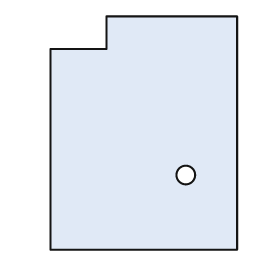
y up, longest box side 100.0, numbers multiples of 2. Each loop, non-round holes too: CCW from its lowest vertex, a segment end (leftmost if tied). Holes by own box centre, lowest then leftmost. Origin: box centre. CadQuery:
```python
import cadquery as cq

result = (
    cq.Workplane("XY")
    .moveTo(-40.0, -50.0)
    .lineTo(40.0, -50.0)
    .lineTo(40.0, 50.0)
    .lineTo(-16.0, 50.0)
    .lineTo(-16.0, 36.0)
    .lineTo(-40.0, 36.0)
    .close()
    .moveTo(18.0, -18.0)
    .circle(4.0)
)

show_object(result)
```